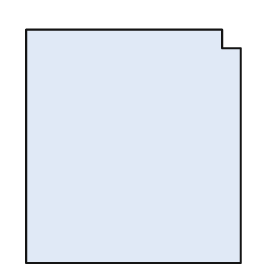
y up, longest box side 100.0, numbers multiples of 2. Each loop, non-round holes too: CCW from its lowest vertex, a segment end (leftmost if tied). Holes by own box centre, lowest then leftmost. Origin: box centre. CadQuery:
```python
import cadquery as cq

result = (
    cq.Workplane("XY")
    .moveTo(-46.0, -50.0)
    .lineTo(46.0, -50.0)
    .lineTo(46.0, 42.0)
    .lineTo(38.0, 42.0)
    .lineTo(38.0, 50.0)
    .lineTo(-46.0, 50.0)
    .close()
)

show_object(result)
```